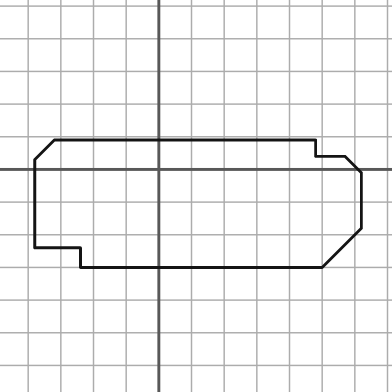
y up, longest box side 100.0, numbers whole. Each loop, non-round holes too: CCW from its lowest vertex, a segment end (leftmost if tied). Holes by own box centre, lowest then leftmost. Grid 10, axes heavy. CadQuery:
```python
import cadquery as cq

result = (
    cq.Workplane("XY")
    .moveTo(-24.0, -30.0)
    .lineTo(50.0, -30.0)
    .lineTo(62.0, -18.0)
    .lineTo(62.0, -1.0)
    .lineTo(57.0, 4.0)
    .lineTo(48.0, 4.0)
    .lineTo(48.0, 9.0)
    .lineTo(-32.0, 9.0)
    .lineTo(-38.0, 3.0)
    .lineTo(-38.0, -24.0)
    .lineTo(-24.0, -24.0)
    .close()
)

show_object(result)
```